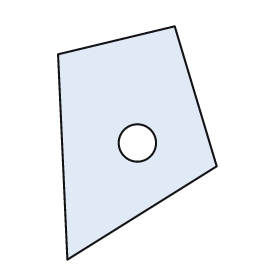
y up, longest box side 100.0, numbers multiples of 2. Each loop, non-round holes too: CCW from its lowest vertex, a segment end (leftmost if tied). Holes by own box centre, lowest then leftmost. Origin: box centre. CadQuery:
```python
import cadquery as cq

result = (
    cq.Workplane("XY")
    .moveTo(-30.0, -50.0)
    .lineTo(34.0, -10.0)
    .lineTo(16.0, 50.0)
    .lineTo(-34.0, 38.0)
    .close()
    .moveTo(0.0, 0.0)
    .circle(8.0)
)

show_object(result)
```